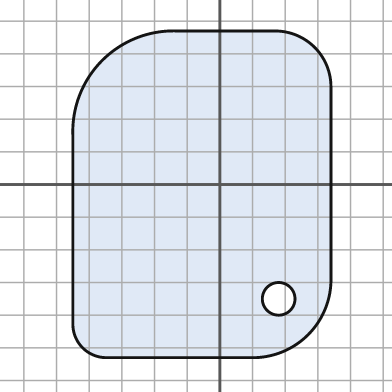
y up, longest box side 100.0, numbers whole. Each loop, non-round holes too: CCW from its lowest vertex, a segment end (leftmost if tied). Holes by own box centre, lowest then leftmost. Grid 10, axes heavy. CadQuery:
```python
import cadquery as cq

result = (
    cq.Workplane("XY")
    .moveTo(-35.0, -53.0)
    .lineTo(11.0, -53.0)
    .threePointArc((27.0, -46.0), (34.0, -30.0))
    .lineTo(34.0, 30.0)
    .threePointArc((29.0, 42.0), (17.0, 47.0))
    .lineTo(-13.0, 47.0)
    .threePointArc((-36.0, 38.0), (-45.0, 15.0))
    .lineTo(-45.0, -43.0)
    .threePointArc((-42.0, -50.0), (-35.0, -53.0))
    .close()
    .moveTo(18.0, -35.0)
    .circle(5.0)
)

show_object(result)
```